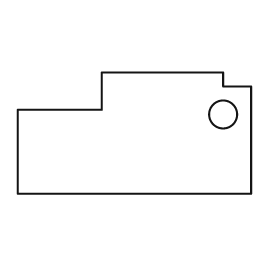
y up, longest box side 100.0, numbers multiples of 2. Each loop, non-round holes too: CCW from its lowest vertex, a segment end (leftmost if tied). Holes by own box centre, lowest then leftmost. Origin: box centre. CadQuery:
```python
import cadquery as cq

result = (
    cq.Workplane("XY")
    .moveTo(-50.0, -26.0)
    .lineTo(50.0, -26.0)
    .lineTo(50.0, 20.0)
    .lineTo(38.0, 20.0)
    .lineTo(38.0, 26.0)
    .lineTo(-14.0, 26.0)
    .lineTo(-14.0, 10.0)
    .lineTo(-50.0, 10.0)
    .close()
    .moveTo(38.0, 8.0)
    .circle(6.0)
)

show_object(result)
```